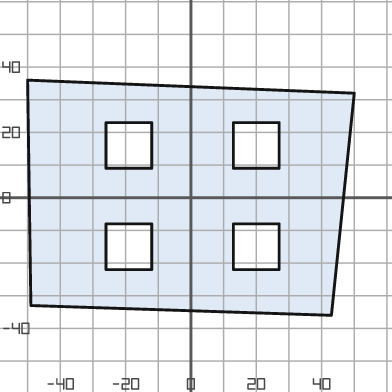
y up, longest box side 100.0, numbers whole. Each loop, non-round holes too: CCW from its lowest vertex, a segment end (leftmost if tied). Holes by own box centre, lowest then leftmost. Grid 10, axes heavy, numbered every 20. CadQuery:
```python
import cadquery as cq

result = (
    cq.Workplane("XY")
    .moveTo(43.0, -36.0)
    .lineTo(50.0, 32.0)
    .lineTo(-50.0, 36.0)
    .lineTo(-49.0, -33.0)
    .close()
    .moveTo(-26.0, -22.0)
    .lineTo(-12.0, -22.0)
    .lineTo(-12.0, -8.0)
    .lineTo(-26.0, -8.0)
    .close()
    .moveTo(13.0, -22.0)
    .lineTo(27.0, -22.0)
    .lineTo(27.0, -8.0)
    .lineTo(13.0, -8.0)
    .close()
    .moveTo(-26.0, 9.0)
    .lineTo(-12.0, 9.0)
    .lineTo(-12.0, 23.0)
    .lineTo(-26.0, 23.0)
    .close()
    .moveTo(13.0, 9.0)
    .lineTo(27.0, 9.0)
    .lineTo(27.0, 23.0)
    .lineTo(13.0, 23.0)
    .close()
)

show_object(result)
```